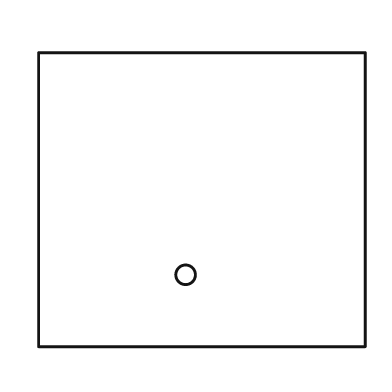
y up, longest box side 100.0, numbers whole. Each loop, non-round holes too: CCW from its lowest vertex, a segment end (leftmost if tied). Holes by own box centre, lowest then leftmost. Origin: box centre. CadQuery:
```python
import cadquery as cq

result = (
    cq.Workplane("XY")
    .moveTo(-50.0, -45.0)
    .lineTo(50.0, -45.0)
    .lineTo(50.0, 45.0)
    .lineTo(-50.0, 45.0)
    .close()
    .moveTo(-5.0, -23.0)
    .circle(3.0)
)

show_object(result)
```